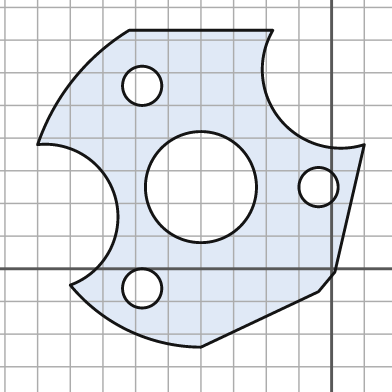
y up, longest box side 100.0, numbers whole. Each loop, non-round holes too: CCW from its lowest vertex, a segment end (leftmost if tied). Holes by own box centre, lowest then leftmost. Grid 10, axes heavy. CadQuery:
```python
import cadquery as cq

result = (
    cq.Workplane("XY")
    .moveTo(-40.0, -24.0)
    .lineTo(-4.0, -7.0)
    .lineTo(1.0, -1.0)
    .lineTo(10.0, 38.0)
    .threePointArc((-16.0, 46.0), (-18.0, 73.0))
    .lineTo(-62.0, 73.0)
    .threePointArc((-79.0, 58.0), (-90.0, 38.0))
    .threePointArc((-66.0, 21.0), (-80.0, -5.0))
    .threePointArc((-62.0, -19.0), (-40.0, -24.0))
    .close()
    .moveTo(-58.0, -6.0)
    .circle(6.0)
    .moveTo(-40.0, 25.0)
    .circle(17.0)
    .moveTo(-4.0, 25.0)
    .circle(6.0)
    .moveTo(-58.0, 56.0)
    .circle(6.0)
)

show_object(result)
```